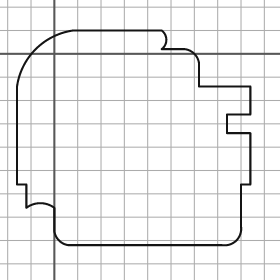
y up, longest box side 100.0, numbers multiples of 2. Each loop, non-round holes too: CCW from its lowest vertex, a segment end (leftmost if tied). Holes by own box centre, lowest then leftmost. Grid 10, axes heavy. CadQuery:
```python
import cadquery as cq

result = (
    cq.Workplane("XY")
    .moveTo(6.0, -82.0)
    .lineTo(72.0, -82.0)
    .threePointArc((78.0, -80.0), (80.0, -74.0))
    .lineTo(80.0, -56.0)
    .lineTo(84.0, -56.0)
    .lineTo(84.0, -34.0)
    .lineTo(74.0, -34.0)
    .lineTo(74.0, -26.0)
    .lineTo(84.0, -26.0)
    .lineTo(84.0, -14.0)
    .lineTo(62.0, -14.0)
    .lineTo(62.0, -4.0)
    .threePointArc((60.0, 0.0), (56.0, 2.0))
    .lineTo(46.0, 2.0)
    .threePointArc((48.0, 6.0), (46.0, 10.0))
    .lineTo(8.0, 10.0)
    .threePointArc((-8.0, 2.0), (-16.0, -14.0))
    .lineTo(-16.0, -56.0)
    .lineTo(-12.0, -56.0)
    .lineTo(-12.0, -66.0)
    .threePointArc((-6.0, -64.0), (0.0, -66.0))
    .lineTo(0.0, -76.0)
    .threePointArc((2.0, -80.0), (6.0, -82.0))
    .close()
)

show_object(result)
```